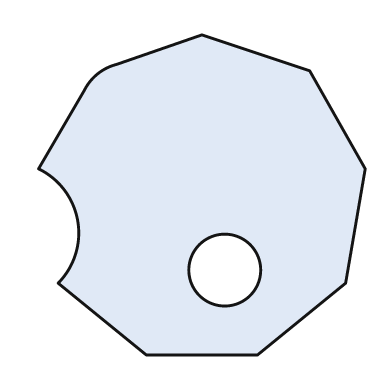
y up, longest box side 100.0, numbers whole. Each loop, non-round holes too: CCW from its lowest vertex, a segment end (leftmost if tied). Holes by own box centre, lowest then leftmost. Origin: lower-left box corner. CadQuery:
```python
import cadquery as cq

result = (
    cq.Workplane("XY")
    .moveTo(33.0, 0.0)
    .lineTo(67.0, 0.0)
    .lineTo(94.0, 22.0)
    .lineTo(100.0, 57.0)
    .lineTo(83.0, 87.0)
    .lineTo(50.0, 98.0)
    .lineTo(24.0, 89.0)
    .threePointArc((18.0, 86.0), (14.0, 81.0))
    .lineTo(0.0, 57.0)
    .threePointArc((12.0, 41.0), (6.0, 22.0))
    .close()
    .moveTo(57.0, 26.0)
    .circle(11.0)
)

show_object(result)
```